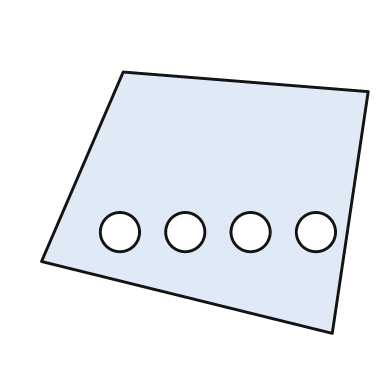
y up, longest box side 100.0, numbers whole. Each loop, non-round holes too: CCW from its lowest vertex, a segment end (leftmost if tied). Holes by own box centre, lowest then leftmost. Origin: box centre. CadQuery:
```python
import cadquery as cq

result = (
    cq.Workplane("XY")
    .moveTo(39.0, -40.0)
    .lineTo(50.0, 34.0)
    .lineTo(-25.0, 40.0)
    .lineTo(-50.0, -18.0)
    .close()
    .moveTo(-26.0, -9.0)
    .circle(6.0)
    .moveTo(-6.0, -9.0)
    .circle(6.0)
    .moveTo(14.0, -9.0)
    .circle(6.0)
    .moveTo(34.0, -9.0)
    .circle(6.0)
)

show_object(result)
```